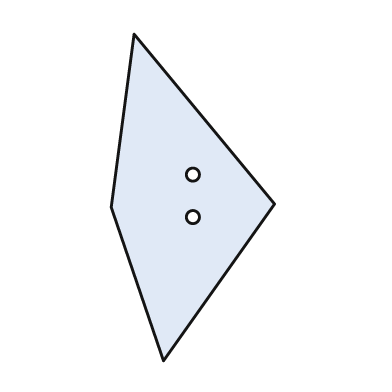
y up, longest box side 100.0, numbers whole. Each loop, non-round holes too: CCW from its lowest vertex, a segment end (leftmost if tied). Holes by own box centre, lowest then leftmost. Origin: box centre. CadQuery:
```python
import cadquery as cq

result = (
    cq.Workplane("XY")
    .moveTo(-9.0, -50.0)
    .lineTo(25.0, -2.0)
    .lineTo(-18.0, 50.0)
    .lineTo(-25.0, -3.0)
    .close()
    .moveTo(0.0, -6.0)
    .circle(2.0)
    .moveTo(0.0, 7.0)
    .circle(2.0)
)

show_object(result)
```